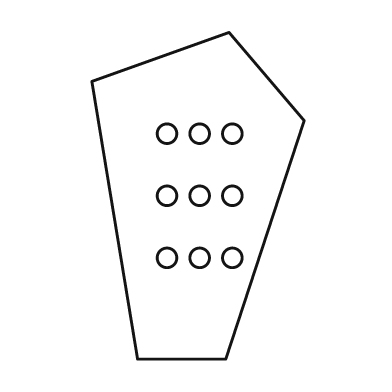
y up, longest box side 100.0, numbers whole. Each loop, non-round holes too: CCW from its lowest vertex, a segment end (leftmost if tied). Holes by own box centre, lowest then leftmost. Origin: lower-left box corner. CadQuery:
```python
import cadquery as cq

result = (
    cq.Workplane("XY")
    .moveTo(14.0, 0.0)
    .lineTo(41.0, 0.0)
    .lineTo(65.0, 73.0)
    .lineTo(42.0, 100.0)
    .lineTo(0.0, 85.0)
    .close()
    .moveTo(23.0, 31.0)
    .circle(3.0)
    .moveTo(33.0, 31.0)
    .circle(3.0)
    .moveTo(43.0, 31.0)
    .circle(3.0)
    .moveTo(23.0, 50.0)
    .circle(3.0)
    .moveTo(33.0, 50.0)
    .circle(3.0)
    .moveTo(43.0, 50.0)
    .circle(3.0)
    .moveTo(23.0, 69.0)
    .circle(3.0)
    .moveTo(33.0, 69.0)
    .circle(3.0)
    .moveTo(43.0, 69.0)
    .circle(3.0)
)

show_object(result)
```